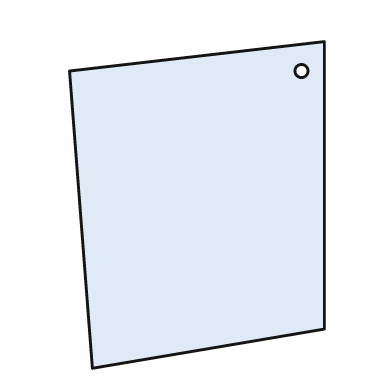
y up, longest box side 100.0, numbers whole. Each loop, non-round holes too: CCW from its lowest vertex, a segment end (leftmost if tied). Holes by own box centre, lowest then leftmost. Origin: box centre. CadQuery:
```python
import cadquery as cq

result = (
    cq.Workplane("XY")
    .moveTo(-32.0, -50.0)
    .lineTo(39.0, -38.0)
    .lineTo(39.0, 50.0)
    .lineTo(-39.0, 41.0)
    .close()
    .moveTo(32.0, 41.0)
    .circle(2.0)
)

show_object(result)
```